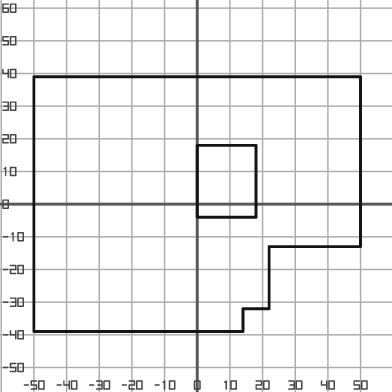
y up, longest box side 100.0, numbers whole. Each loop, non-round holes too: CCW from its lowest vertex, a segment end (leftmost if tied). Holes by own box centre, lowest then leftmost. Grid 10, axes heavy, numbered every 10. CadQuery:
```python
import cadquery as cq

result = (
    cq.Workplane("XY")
    .moveTo(-50.0, -39.0)
    .lineTo(14.0, -39.0)
    .lineTo(14.0, -32.0)
    .lineTo(22.0, -32.0)
    .lineTo(22.0, -13.0)
    .lineTo(50.0, -13.0)
    .lineTo(50.0, 39.0)
    .lineTo(-50.0, 39.0)
    .close()
    .moveTo(0.0, -4.0)
    .lineTo(18.0, -4.0)
    .lineTo(18.0, 18.0)
    .lineTo(0.0, 18.0)
    .close()
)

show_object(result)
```